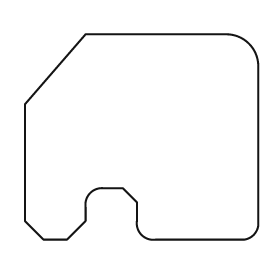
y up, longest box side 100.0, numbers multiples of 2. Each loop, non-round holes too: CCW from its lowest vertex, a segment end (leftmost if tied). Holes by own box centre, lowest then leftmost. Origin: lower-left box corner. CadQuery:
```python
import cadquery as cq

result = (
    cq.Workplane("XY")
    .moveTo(8.0, 0.0)
    .lineTo(18.0, 0.0)
    .lineTo(26.0, 8.0)
    .lineTo(26.0, 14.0)
    .threePointArc((28.0, 20.0), (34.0, 22.0))
    .lineTo(42.0, 22.0)
    .lineTo(48.0, 16.0)
    .lineTo(48.0, 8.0)
    .threePointArc((50.0, 2.0), (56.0, 0.0))
    .lineTo(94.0, 0.0)
    .threePointArc((98.0, 2.0), (100.0, 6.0))
    .lineTo(100.0, 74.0)
    .threePointArc((96.0, 84.0), (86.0, 88.0))
    .lineTo(26.0, 88.0)
    .lineTo(0.0, 58.0)
    .lineTo(0.0, 8.0)
    .close()
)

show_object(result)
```